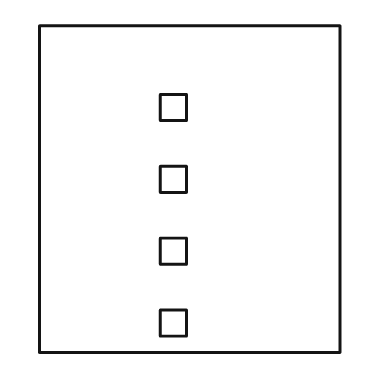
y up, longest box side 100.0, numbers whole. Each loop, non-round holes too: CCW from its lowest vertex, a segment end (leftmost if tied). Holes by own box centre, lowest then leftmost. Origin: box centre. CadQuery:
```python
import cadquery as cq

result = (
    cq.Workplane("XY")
    .moveTo(-46.0, -50.0)
    .lineTo(46.0, -50.0)
    .lineTo(46.0, 50.0)
    .lineTo(-46.0, 50.0)
    .close()
    .moveTo(-9.0, -45.0)
    .lineTo(-1.0, -45.0)
    .lineTo(-1.0, -37.0)
    .lineTo(-9.0, -37.0)
    .close()
    .moveTo(-9.0, -23.0)
    .lineTo(-1.0, -23.0)
    .lineTo(-1.0, -15.0)
    .lineTo(-9.0, -15.0)
    .close()
    .moveTo(-9.0, -1.0)
    .lineTo(-1.0, -1.0)
    .lineTo(-1.0, 7.0)
    .lineTo(-9.0, 7.0)
    .close()
    .moveTo(-9.0, 21.0)
    .lineTo(-1.0, 21.0)
    .lineTo(-1.0, 29.0)
    .lineTo(-9.0, 29.0)
    .close()
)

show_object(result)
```